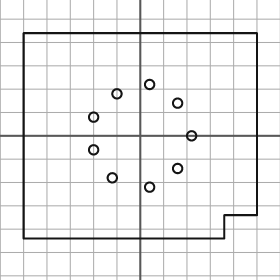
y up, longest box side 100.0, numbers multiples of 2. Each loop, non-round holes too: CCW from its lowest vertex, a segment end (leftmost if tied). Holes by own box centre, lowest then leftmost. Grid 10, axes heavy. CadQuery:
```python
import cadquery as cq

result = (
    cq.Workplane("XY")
    .moveTo(-50.0, -44.0)
    .lineTo(36.0, -44.0)
    .lineTo(36.0, -34.0)
    .lineTo(50.0, -34.0)
    .lineTo(50.0, 44.0)
    .lineTo(-50.0, 44.0)
    .close()
    .moveTo(4.0, -22.0)
    .circle(2.0)
    .moveTo(-12.0, -18.0)
    .circle(2.0)
    .moveTo(16.0, -14.0)
    .circle(2.0)
    .moveTo(-20.0, -6.0)
    .circle(2.0)
    .moveTo(22.0, 0.0)
    .circle(2.0)
    .moveTo(-20.0, 8.0)
    .circle(2.0)
    .moveTo(16.0, 14.0)
    .circle(2.0)
    .moveTo(-10.0, 18.0)
    .circle(2.0)
    .moveTo(4.0, 22.0)
    .circle(2.0)
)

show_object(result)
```